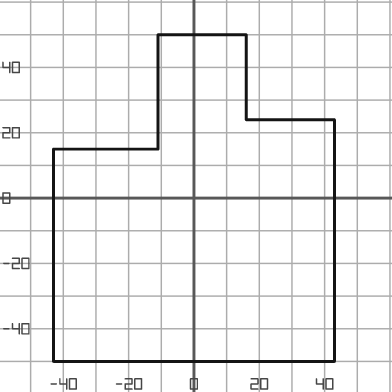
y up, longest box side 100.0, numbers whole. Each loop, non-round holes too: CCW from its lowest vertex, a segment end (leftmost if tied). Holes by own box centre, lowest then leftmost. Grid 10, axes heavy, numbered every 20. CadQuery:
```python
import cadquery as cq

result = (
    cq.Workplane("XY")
    .moveTo(-43.0, -50.0)
    .lineTo(43.0, -50.0)
    .lineTo(43.0, 24.0)
    .lineTo(16.0, 24.0)
    .lineTo(16.0, 50.0)
    .lineTo(-11.0, 50.0)
    .lineTo(-11.0, 15.0)
    .lineTo(-43.0, 15.0)
    .close()
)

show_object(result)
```